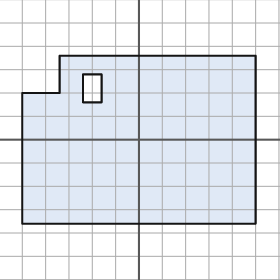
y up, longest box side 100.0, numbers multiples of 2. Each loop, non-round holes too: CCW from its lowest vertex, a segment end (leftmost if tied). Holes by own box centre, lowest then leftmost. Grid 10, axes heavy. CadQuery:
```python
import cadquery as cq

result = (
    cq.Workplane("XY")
    .moveTo(-50.0, -36.0)
    .lineTo(50.0, -36.0)
    .lineTo(50.0, 36.0)
    .lineTo(-34.0, 36.0)
    .lineTo(-34.0, 20.0)
    .lineTo(-50.0, 20.0)
    .close()
    .moveTo(-24.0, 16.0)
    .lineTo(-16.0, 16.0)
    .lineTo(-16.0, 28.0)
    .lineTo(-24.0, 28.0)
    .close()
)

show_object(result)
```